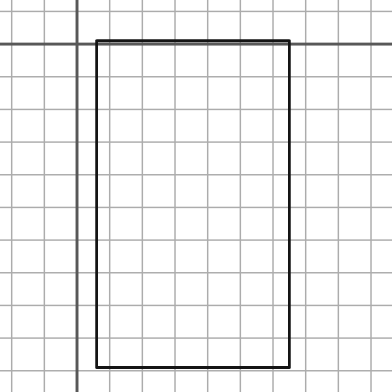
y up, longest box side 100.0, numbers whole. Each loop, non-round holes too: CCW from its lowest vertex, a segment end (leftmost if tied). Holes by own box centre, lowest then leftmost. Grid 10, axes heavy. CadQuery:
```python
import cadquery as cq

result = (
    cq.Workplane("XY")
    .moveTo(6.0, -99.0)
    .lineTo(65.0, -99.0)
    .lineTo(65.0, 1.0)
    .lineTo(6.0, 1.0)
    .close()
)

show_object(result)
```